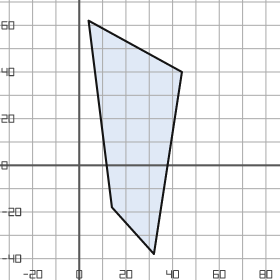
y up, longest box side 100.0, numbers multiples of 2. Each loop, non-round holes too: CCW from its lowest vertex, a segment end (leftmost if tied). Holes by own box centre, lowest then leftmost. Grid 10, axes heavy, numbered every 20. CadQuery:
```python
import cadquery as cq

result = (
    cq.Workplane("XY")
    .moveTo(32.0, -38.0)
    .lineTo(44.0, 40.0)
    .lineTo(4.0, 62.0)
    .lineTo(14.0, -18.0)
    .close()
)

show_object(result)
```